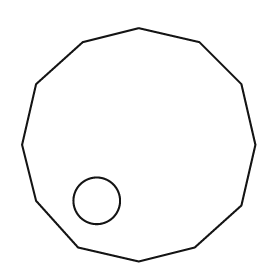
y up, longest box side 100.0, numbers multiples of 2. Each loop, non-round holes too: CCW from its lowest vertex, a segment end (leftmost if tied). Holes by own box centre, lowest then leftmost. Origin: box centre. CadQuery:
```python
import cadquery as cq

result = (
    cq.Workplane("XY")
    .moveTo(0.0, -50.0)
    .lineTo(24.0, -44.0)
    .lineTo(44.0, -26.0)
    .lineTo(50.0, 0.0)
    .lineTo(44.0, 26.0)
    .lineTo(26.0, 44.0)
    .lineTo(0.0, 50.0)
    .lineTo(-24.0, 44.0)
    .lineTo(-44.0, 26.0)
    .lineTo(-50.0, 0.0)
    .lineTo(-44.0, -24.0)
    .lineTo(-26.0, -44.0)
    .close()
    .moveTo(-18.0, -24.0)
    .circle(10.0)
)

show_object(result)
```